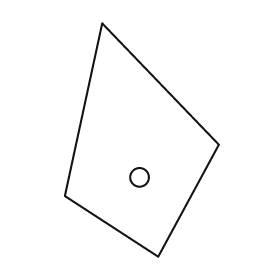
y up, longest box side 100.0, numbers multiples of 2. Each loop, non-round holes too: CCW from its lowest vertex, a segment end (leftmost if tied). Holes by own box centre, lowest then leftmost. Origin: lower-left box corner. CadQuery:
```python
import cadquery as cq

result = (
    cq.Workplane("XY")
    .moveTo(40.0, 0.0)
    .lineTo(66.0, 48.0)
    .lineTo(16.0, 100.0)
    .lineTo(0.0, 26.0)
    .close()
    .moveTo(32.0, 34.0)
    .circle(4.0)
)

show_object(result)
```